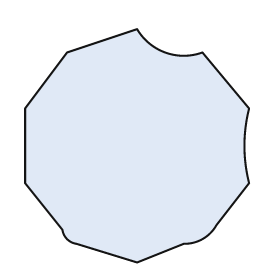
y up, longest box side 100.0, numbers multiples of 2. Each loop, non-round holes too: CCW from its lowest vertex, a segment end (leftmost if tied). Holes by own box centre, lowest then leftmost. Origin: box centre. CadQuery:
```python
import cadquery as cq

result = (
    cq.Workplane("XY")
    .moveTo(0.0, -50.0)
    .lineTo(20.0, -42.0)
    .threePointArc((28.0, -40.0), (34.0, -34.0))
    .lineTo(48.0, -16.0)
    .threePointArc((46.0, 0.0), (48.0, 16.0))
    .lineTo(28.0, 40.0)
    .threePointArc((12.0, 40.0), (0.0, 50.0))
    .lineTo(-30.0, 40.0)
    .lineTo(-48.0, 16.0)
    .lineTo(-48.0, -16.0)
    .lineTo(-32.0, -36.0)
    .threePointArc((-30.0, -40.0), (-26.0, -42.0))
    .close()
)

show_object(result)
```